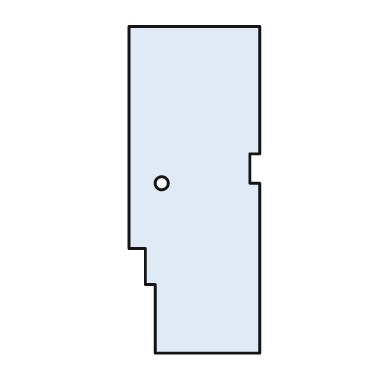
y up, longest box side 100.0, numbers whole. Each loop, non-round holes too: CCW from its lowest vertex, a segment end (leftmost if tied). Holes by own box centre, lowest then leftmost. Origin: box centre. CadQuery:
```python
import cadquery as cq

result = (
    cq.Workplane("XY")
    .moveTo(-12.0, -50.0)
    .lineTo(20.0, -50.0)
    .lineTo(20.0, 2.0)
    .lineTo(17.0, 2.0)
    .lineTo(17.0, 11.0)
    .lineTo(20.0, 11.0)
    .lineTo(20.0, 50.0)
    .lineTo(-20.0, 50.0)
    .lineTo(-20.0, -18.0)
    .lineTo(-15.0, -18.0)
    .lineTo(-15.0, -29.0)
    .lineTo(-12.0, -29.0)
    .close()
    .moveTo(-10.0, 2.0)
    .circle(2.0)
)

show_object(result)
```